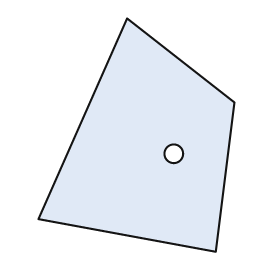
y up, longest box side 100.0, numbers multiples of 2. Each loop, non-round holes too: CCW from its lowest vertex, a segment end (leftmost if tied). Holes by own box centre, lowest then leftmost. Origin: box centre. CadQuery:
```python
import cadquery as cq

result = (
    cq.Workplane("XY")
    .moveTo(34.0, -50.0)
    .lineTo(42.0, 14.0)
    .lineTo(-4.0, 50.0)
    .lineTo(-42.0, -36.0)
    .close()
    .moveTo(16.0, -8.0)
    .circle(4.0)
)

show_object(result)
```